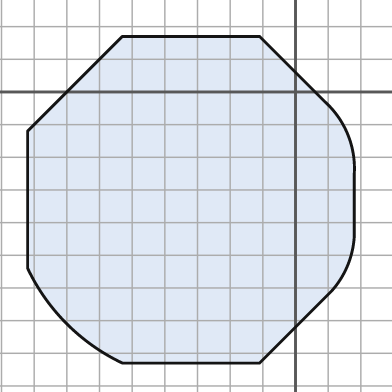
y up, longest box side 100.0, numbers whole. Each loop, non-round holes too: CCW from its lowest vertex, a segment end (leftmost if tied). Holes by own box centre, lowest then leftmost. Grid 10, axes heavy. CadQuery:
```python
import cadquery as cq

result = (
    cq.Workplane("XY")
    .moveTo(-53.0, -83.0)
    .lineTo(-11.0, -83.0)
    .lineTo(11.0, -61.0)
    .threePointArc((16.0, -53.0), (18.0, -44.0))
    .lineTo(18.0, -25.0)
    .threePointArc((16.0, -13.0), (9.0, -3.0))
    .lineTo(-11.0, 17.0)
    .lineTo(-53.0, 17.0)
    .lineTo(-82.0, -12.0)
    .lineTo(-82.0, -54.0)
    .threePointArc((-70.0, -71.0), (-53.0, -83.0))
    .close()
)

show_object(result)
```